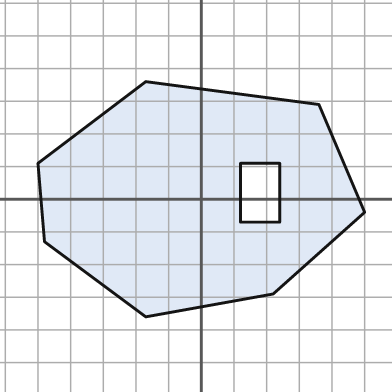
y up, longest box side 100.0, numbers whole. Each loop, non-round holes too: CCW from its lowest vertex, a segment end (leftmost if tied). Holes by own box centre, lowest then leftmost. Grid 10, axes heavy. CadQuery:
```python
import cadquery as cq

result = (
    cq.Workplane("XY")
    .moveTo(-17.0, -36.0)
    .lineTo(22.0, -29.0)
    .lineTo(50.0, -4.0)
    .lineTo(36.0, 29.0)
    .lineTo(-17.0, 36.0)
    .lineTo(-50.0, 11.0)
    .lineTo(-48.0, -13.0)
    .close()
    .moveTo(12.0, -7.0)
    .lineTo(24.0, -7.0)
    .lineTo(24.0, 11.0)
    .lineTo(12.0, 11.0)
    .close()
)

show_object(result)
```